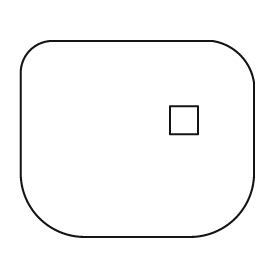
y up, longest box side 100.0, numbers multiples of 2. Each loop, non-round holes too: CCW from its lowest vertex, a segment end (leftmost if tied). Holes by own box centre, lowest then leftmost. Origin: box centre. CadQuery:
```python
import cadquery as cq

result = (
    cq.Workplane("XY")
    .moveTo(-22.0, -42.0)
    .lineTo(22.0, -42.0)
    .threePointArc((42.0, -34.0), (50.0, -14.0))
    .lineTo(50.0, 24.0)
    .threePointArc((44.0, 36.0), (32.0, 42.0))
    .lineTo(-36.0, 42.0)
    .threePointArc((-46.0, 38.0), (-50.0, 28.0))
    .lineTo(-50.0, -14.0)
    .threePointArc((-42.0, -34.0), (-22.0, -42.0))
    .close()
    .moveTo(14.0, 2.0)
    .lineTo(26.0, 2.0)
    .lineTo(26.0, 14.0)
    .lineTo(14.0, 14.0)
    .close()
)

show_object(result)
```